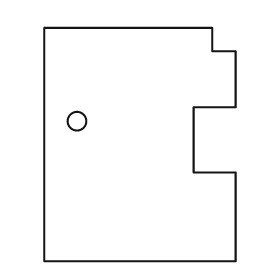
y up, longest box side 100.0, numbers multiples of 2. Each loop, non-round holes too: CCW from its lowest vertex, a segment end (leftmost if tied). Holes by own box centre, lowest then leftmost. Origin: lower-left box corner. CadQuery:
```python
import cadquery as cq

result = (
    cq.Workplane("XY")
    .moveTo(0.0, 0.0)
    .lineTo(82.0, 0.0)
    .lineTo(82.0, 38.0)
    .lineTo(64.0, 38.0)
    .lineTo(64.0, 66.0)
    .lineTo(82.0, 66.0)
    .lineTo(82.0, 90.0)
    .lineTo(72.0, 90.0)
    .lineTo(72.0, 100.0)
    .lineTo(0.0, 100.0)
    .close()
    .moveTo(14.0, 60.0)
    .circle(4.0)
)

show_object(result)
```